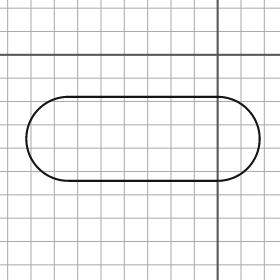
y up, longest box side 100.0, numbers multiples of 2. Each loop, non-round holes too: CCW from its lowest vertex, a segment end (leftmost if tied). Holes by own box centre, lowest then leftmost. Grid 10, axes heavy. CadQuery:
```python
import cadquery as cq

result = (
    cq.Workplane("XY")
    .moveTo(-64.0, -54.0)
    .lineTo(0.0, -54.0)
    .threePointArc((18.0, -36.0), (0.0, -18.0))
    .lineTo(-64.0, -18.0)
    .threePointArc((-82.0, -36.0), (-64.0, -54.0))
    .close()
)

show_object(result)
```